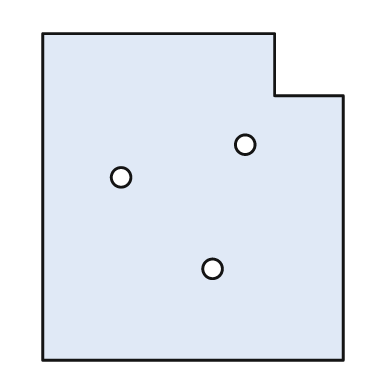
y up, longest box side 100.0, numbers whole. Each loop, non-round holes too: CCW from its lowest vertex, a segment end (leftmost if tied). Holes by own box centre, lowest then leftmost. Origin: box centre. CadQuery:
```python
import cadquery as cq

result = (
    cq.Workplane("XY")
    .moveTo(-46.0, -50.0)
    .lineTo(46.0, -50.0)
    .lineTo(46.0, 31.0)
    .lineTo(25.0, 31.0)
    .lineTo(25.0, 50.0)
    .lineTo(-46.0, 50.0)
    .close()
    .moveTo(6.0, -22.0)
    .circle(3.0)
    .moveTo(-22.0, 6.0)
    .circle(3.0)
    .moveTo(16.0, 16.0)
    .circle(3.0)
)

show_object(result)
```